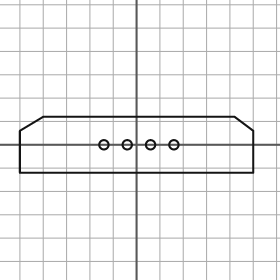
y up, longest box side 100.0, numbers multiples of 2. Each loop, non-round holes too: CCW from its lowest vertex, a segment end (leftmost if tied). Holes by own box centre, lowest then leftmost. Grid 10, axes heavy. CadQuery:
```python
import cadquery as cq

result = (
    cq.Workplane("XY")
    .moveTo(-50.0, -12.0)
    .lineTo(50.0, -12.0)
    .lineTo(50.0, 6.0)
    .lineTo(42.0, 12.0)
    .lineTo(-40.0, 12.0)
    .lineTo(-50.0, 6.0)
    .close()
    .moveTo(-14.0, 0.0)
    .circle(2.0)
    .moveTo(-4.0, 0.0)
    .circle(2.0)
    .moveTo(6.0, 0.0)
    .circle(2.0)
    .moveTo(16.0, 0.0)
    .circle(2.0)
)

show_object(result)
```